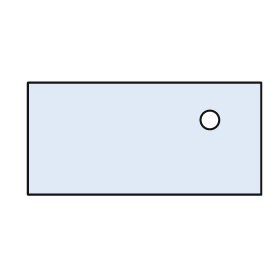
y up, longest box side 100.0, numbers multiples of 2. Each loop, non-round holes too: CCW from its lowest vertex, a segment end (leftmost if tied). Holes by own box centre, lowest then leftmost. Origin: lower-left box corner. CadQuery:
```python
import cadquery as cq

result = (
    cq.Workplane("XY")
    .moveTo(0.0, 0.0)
    .lineTo(100.0, 0.0)
    .lineTo(100.0, 48.0)
    .lineTo(0.0, 48.0)
    .close()
    .moveTo(78.0, 32.0)
    .circle(4.0)
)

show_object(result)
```